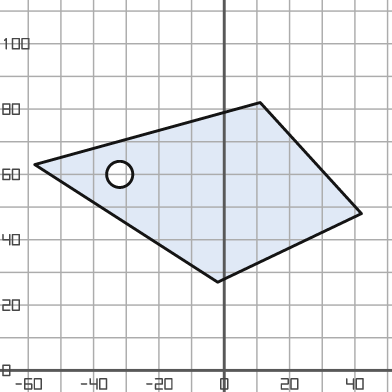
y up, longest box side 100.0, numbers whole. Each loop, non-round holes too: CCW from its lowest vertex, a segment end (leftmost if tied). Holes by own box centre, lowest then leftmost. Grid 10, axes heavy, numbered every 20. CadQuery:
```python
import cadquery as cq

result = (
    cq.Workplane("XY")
    .moveTo(-2.0, 27.0)
    .lineTo(42.0, 48.0)
    .lineTo(11.0, 82.0)
    .lineTo(-58.0, 63.0)
    .close()
    .moveTo(-32.0, 60.0)
    .circle(4.0)
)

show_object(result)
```